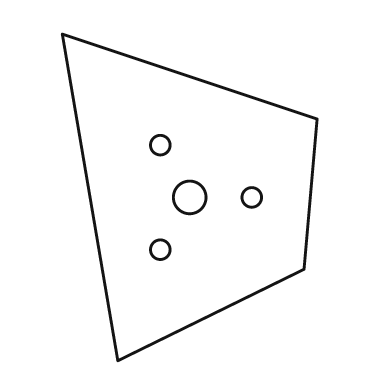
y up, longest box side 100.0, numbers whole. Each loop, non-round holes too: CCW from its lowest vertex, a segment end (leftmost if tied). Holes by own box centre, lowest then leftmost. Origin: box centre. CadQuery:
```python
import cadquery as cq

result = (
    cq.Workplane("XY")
    .moveTo(-22.0, -50.0)
    .lineTo(35.0, -22.0)
    .lineTo(39.0, 24.0)
    .lineTo(-39.0, 50.0)
    .close()
    .moveTo(-9.0, -16.0)
    .circle(3.0)
    .moveTo(0.0, 0.0)
    .circle(5.0)
    .moveTo(19.0, 0.0)
    .circle(3.0)
    .moveTo(-9.0, 16.0)
    .circle(3.0)
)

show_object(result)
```